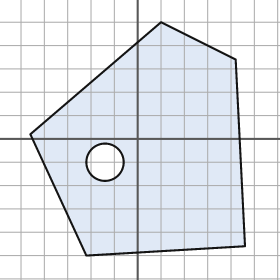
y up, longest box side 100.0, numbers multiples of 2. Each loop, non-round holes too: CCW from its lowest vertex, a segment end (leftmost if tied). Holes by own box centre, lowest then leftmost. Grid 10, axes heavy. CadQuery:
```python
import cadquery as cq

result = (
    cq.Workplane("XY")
    .moveTo(-22.0, -50.0)
    .lineTo(46.0, -46.0)
    .lineTo(42.0, 34.0)
    .lineTo(10.0, 50.0)
    .lineTo(-46.0, 2.0)
    .close()
    .moveTo(-14.0, -10.0)
    .circle(8.0)
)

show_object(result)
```